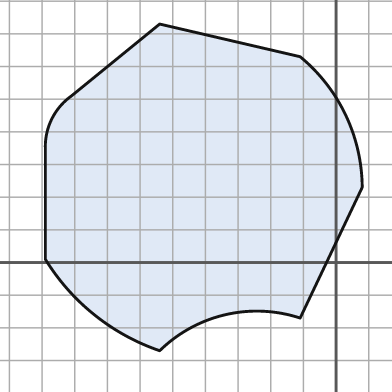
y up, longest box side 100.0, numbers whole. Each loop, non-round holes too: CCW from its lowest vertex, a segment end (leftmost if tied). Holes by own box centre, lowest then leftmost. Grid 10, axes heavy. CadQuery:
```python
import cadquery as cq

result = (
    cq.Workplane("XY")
    .moveTo(-54.0, -27.0)
    .threePointArc((-34.0, -16.0), (-11.0, -17.0))
    .lineTo(8.0, 23.0)
    .threePointArc((3.0, 45.0), (-11.0, 63.0))
    .lineTo(-54.0, 73.0)
    .lineTo(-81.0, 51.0)
    .threePointArc((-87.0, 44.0), (-89.0, 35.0))
    .lineTo(-89.0, 1.0)
    .threePointArc((-74.0, -16.0), (-54.0, -27.0))
    .close()
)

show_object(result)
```